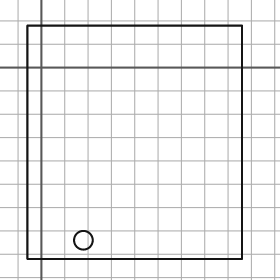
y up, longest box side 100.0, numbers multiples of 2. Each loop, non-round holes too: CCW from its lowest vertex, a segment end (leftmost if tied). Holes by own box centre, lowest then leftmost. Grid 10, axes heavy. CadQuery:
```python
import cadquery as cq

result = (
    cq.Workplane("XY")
    .moveTo(-6.0, -82.0)
    .lineTo(86.0, -82.0)
    .lineTo(86.0, 18.0)
    .lineTo(-6.0, 18.0)
    .close()
    .moveTo(18.0, -74.0)
    .circle(4.0)
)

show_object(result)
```